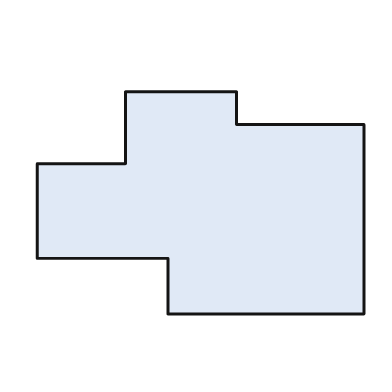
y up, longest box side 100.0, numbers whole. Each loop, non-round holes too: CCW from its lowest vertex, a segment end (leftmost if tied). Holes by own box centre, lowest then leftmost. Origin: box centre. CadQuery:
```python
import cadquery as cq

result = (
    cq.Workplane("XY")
    .moveTo(-10.0, -34.0)
    .lineTo(50.0, -34.0)
    .lineTo(50.0, 24.0)
    .lineTo(11.0, 24.0)
    .lineTo(11.0, 34.0)
    .lineTo(-23.0, 34.0)
    .lineTo(-23.0, 12.0)
    .lineTo(-50.0, 12.0)
    .lineTo(-50.0, -17.0)
    .lineTo(-10.0, -17.0)
    .close()
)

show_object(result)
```